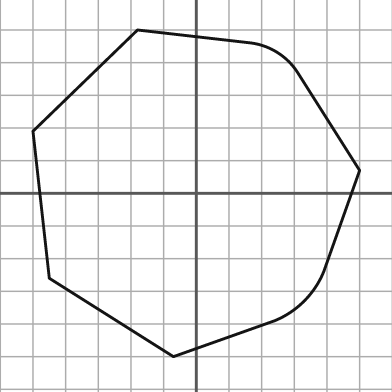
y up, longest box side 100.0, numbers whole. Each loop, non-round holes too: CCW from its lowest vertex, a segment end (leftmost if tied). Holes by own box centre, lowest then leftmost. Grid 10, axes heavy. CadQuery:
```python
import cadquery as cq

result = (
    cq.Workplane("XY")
    .moveTo(-7.0, -50.0)
    .lineTo(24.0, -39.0)
    .threePointArc((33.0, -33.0), (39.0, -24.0))
    .lineTo(50.0, 7.0)
    .lineTo(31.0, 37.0)
    .threePointArc((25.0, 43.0), (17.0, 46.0))
    .lineTo(-18.0, 50.0)
    .lineTo(-50.0, 19.0)
    .lineTo(-45.0, -26.0)
    .close()
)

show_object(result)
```